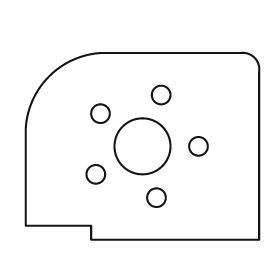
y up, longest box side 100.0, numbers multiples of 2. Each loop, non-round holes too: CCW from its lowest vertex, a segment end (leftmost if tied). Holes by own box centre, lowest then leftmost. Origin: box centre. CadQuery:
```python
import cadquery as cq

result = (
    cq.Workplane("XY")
    .moveTo(-22.0, -40.0)
    .lineTo(50.0, -40.0)
    .lineTo(50.0, 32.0)
    .threePointArc((48.0, 38.0), (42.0, 40.0))
    .lineTo(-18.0, 40.0)
    .threePointArc((-40.0, 30.0), (-50.0, 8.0))
    .lineTo(-50.0, -34.0)
    .lineTo(-22.0, -34.0)
    .close()
    .moveTo(6.0, -22.0)
    .circle(4.0)
    .moveTo(-20.0, -12.0)
    .circle(4.0)
    .moveTo(0.0, 0.0)
    .circle(12.0)
    .moveTo(24.0, 0.0)
    .circle(4.0)
    .moveTo(-18.0, 14.0)
    .circle(4.0)
    .moveTo(8.0, 22.0)
    .circle(4.0)
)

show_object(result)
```